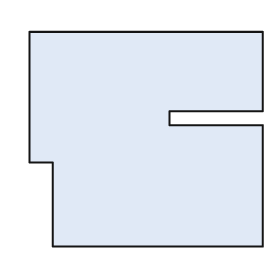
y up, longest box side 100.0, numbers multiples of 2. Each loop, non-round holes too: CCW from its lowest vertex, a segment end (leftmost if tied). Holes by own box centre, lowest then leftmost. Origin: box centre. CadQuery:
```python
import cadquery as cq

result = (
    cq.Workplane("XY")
    .moveTo(-40.0, -46.0)
    .lineTo(50.0, -46.0)
    .lineTo(50.0, 6.0)
    .lineTo(10.0, 6.0)
    .lineTo(10.0, 12.0)
    .lineTo(50.0, 12.0)
    .lineTo(50.0, 46.0)
    .lineTo(-50.0, 46.0)
    .lineTo(-50.0, -10.0)
    .lineTo(-40.0, -10.0)
    .close()
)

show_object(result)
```